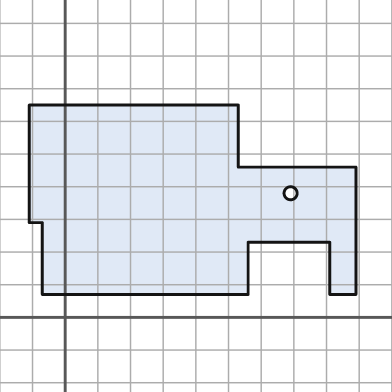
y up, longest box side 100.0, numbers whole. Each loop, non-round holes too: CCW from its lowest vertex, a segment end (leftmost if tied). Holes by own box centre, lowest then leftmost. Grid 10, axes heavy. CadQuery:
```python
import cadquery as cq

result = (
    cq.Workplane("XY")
    .moveTo(-7.0, 7.0)
    .lineTo(56.0, 7.0)
    .lineTo(56.0, 23.0)
    .lineTo(81.0, 23.0)
    .lineTo(81.0, 7.0)
    .lineTo(89.0, 7.0)
    .lineTo(89.0, 46.0)
    .lineTo(53.0, 46.0)
    .lineTo(53.0, 65.0)
    .lineTo(-11.0, 65.0)
    .lineTo(-11.0, 29.0)
    .lineTo(-7.0, 29.0)
    .close()
    .moveTo(69.0, 38.0)
    .circle(2.0)
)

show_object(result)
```